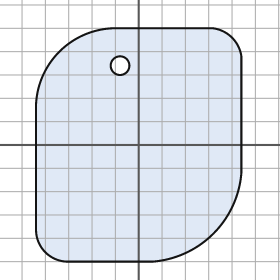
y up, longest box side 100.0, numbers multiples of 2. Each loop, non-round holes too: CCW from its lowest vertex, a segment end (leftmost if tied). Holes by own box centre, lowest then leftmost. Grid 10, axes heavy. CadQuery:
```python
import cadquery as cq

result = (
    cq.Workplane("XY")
    .moveTo(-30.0, -50.0)
    .lineTo(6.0, -50.0)
    .threePointArc((32.0, -38.0), (44.0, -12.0))
    .lineTo(44.0, 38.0)
    .threePointArc((40.0, 46.0), (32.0, 50.0))
    .lineTo(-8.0, 50.0)
    .threePointArc((-34.0, 40.0), (-44.0, 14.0))
    .lineTo(-44.0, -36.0)
    .threePointArc((-40.0, -46.0), (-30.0, -50.0))
    .close()
    .moveTo(-8.0, 34.0)
    .circle(4.0)
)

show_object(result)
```